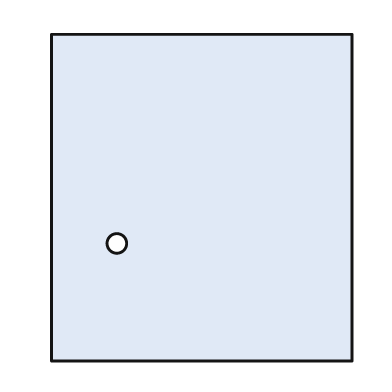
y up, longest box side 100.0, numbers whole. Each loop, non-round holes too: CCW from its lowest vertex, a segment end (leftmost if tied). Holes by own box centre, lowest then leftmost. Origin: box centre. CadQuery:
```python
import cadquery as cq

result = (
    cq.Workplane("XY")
    .moveTo(-46.0, -50.0)
    .lineTo(46.0, -50.0)
    .lineTo(46.0, 50.0)
    .lineTo(-46.0, 50.0)
    .close()
    .moveTo(-26.0, -14.0)
    .circle(3.0)
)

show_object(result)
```